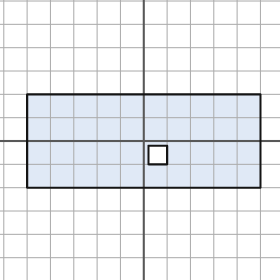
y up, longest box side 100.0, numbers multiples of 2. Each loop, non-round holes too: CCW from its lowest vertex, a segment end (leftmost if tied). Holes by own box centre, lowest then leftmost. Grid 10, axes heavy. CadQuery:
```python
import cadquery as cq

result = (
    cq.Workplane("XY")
    .moveTo(-50.0, -20.0)
    .lineTo(50.0, -20.0)
    .lineTo(50.0, 20.0)
    .lineTo(-50.0, 20.0)
    .close()
    .moveTo(2.0, -10.0)
    .lineTo(10.0, -10.0)
    .lineTo(10.0, -2.0)
    .lineTo(2.0, -2.0)
    .close()
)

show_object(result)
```